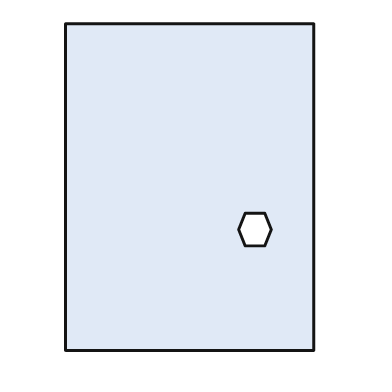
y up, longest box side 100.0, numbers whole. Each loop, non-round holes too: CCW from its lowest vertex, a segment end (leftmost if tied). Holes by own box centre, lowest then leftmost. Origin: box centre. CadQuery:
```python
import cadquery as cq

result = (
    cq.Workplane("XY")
    .moveTo(-38.0, -50.0)
    .lineTo(38.0, -50.0)
    .lineTo(38.0, 50.0)
    .lineTo(-38.0, 50.0)
    .close()
    .moveTo(17.0, -18.0)
    .lineTo(23.0, -18.0)
    .lineTo(25.0, -13.0)
    .lineTo(23.0, -8.0)
    .lineTo(17.0, -8.0)
    .lineTo(15.0, -13.0)
    .close()
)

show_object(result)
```